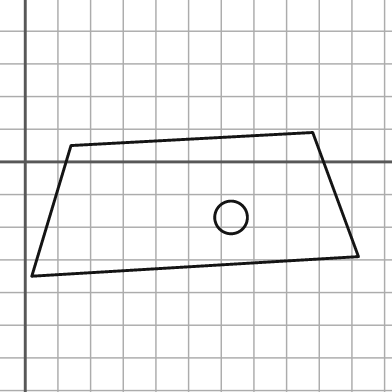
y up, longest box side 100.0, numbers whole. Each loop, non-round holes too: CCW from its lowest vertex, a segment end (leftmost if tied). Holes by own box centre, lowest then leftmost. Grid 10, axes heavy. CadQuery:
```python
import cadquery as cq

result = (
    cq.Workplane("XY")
    .moveTo(2.0, -35.0)
    .lineTo(102.0, -29.0)
    .lineTo(88.0, 9.0)
    .lineTo(14.0, 5.0)
    .close()
    .moveTo(63.0, -17.0)
    .circle(5.0)
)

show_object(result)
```